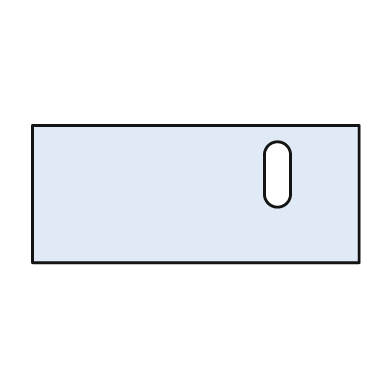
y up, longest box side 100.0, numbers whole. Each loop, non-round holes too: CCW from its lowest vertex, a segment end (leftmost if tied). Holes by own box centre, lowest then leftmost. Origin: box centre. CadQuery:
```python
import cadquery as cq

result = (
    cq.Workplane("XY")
    .moveTo(-50.0, -21.0)
    .lineTo(50.0, -21.0)
    .lineTo(50.0, 21.0)
    .lineTo(-50.0, 21.0)
    .close()
    .moveTo(21.0, 0.0)
    .threePointArc((25.0, -4.0), (29.0, 0.0))
    .lineTo(29.0, 12.0)
    .threePointArc((25.0, 16.0), (21.0, 12.0))
    .close()
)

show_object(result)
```